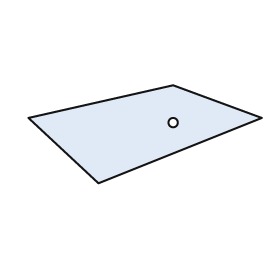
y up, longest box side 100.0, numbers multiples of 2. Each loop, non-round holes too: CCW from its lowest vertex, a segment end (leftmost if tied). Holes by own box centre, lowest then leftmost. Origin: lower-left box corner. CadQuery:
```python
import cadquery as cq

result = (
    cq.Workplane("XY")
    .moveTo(30.0, 0.0)
    .lineTo(100.0, 28.0)
    .lineTo(62.0, 42.0)
    .lineTo(0.0, 28.0)
    .close()
    .moveTo(62.0, 26.0)
    .circle(2.0)
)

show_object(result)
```